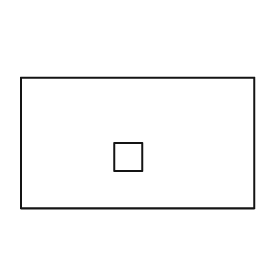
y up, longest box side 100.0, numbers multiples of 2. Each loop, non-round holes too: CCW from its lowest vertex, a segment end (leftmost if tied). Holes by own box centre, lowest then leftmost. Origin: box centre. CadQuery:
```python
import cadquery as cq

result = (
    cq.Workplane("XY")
    .moveTo(-50.0, -28.0)
    .lineTo(50.0, -28.0)
    .lineTo(50.0, 28.0)
    .lineTo(-50.0, 28.0)
    .close()
    .moveTo(-10.0, -12.0)
    .lineTo(2.0, -12.0)
    .lineTo(2.0, 0.0)
    .lineTo(-10.0, 0.0)
    .close()
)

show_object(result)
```